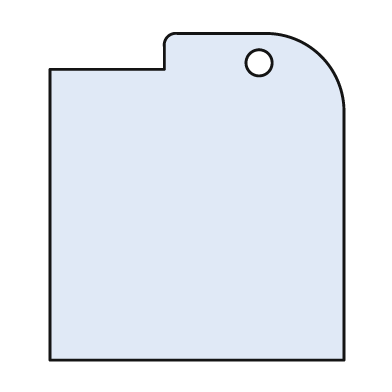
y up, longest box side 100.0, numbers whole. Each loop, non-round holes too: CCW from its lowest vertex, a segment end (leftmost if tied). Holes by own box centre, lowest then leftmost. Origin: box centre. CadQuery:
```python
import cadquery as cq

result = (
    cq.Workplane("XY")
    .moveTo(-45.0, -50.0)
    .lineTo(45.0, -50.0)
    .lineTo(45.0, 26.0)
    .threePointArc((38.0, 43.0), (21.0, 50.0))
    .lineTo(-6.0, 50.0)
    .threePointArc((-9.0, 49.0), (-10.0, 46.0))
    .lineTo(-10.0, 39.0)
    .lineTo(-45.0, 39.0)
    .close()
    .moveTo(19.0, 41.0)
    .circle(4.0)
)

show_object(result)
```